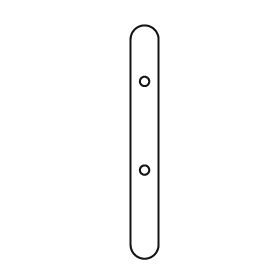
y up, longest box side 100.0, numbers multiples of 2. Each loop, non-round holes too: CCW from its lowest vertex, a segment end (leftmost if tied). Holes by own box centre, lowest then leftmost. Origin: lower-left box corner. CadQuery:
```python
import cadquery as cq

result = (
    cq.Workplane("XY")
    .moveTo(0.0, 6.0)
    .threePointArc((6.0, 0.0), (12.0, 6.0))
    .lineTo(12.0, 94.0)
    .threePointArc((6.0, 100.0), (0.0, 94.0))
    .close()
    .moveTo(6.0, 38.0)
    .circle(2.0)
    .moveTo(6.0, 76.0)
    .circle(2.0)
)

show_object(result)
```